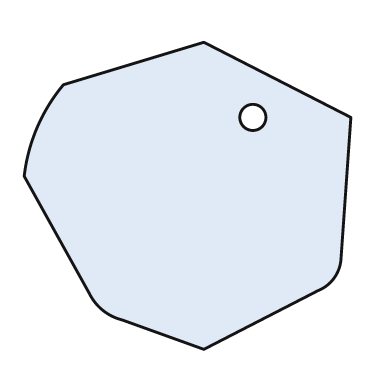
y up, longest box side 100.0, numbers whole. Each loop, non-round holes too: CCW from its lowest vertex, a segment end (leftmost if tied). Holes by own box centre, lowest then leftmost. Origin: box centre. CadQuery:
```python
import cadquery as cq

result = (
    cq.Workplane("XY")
    .moveTo(5.0, -47.0)
    .lineTo(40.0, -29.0)
    .threePointArc((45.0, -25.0), (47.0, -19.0))
    .lineTo(50.0, 24.0)
    .lineTo(5.0, 47.0)
    .lineTo(-38.0, 34.0)
    .threePointArc((-46.0, 21.0), (-50.0, 6.0))
    .lineTo(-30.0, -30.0)
    .threePointArc((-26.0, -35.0), (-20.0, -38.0))
    .close()
    .moveTo(20.0, 24.0)
    .circle(4.0)
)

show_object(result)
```